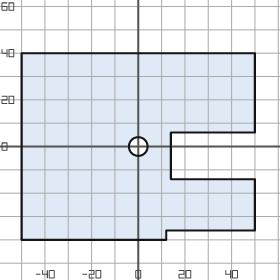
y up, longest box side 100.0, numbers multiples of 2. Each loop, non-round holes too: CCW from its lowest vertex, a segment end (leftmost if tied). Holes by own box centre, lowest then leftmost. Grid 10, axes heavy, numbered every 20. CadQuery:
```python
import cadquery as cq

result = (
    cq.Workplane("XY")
    .moveTo(-50.0, -40.0)
    .lineTo(12.0, -40.0)
    .lineTo(12.0, -36.0)
    .lineTo(50.0, -36.0)
    .lineTo(50.0, -14.0)
    .lineTo(14.0, -14.0)
    .lineTo(14.0, 6.0)
    .lineTo(50.0, 6.0)
    .lineTo(50.0, 40.0)
    .lineTo(-50.0, 40.0)
    .close()
    .moveTo(0.0, 0.0)
    .circle(4.0)
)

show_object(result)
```